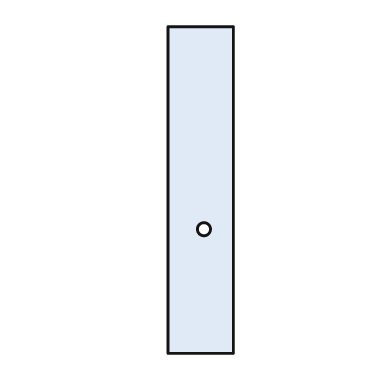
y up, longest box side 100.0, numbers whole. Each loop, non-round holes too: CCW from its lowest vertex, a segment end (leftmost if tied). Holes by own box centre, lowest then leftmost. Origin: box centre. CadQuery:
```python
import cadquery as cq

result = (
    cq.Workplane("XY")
    .moveTo(-10.0, -50.0)
    .lineTo(10.0, -50.0)
    .lineTo(10.0, 50.0)
    .lineTo(-10.0, 50.0)
    .close()
    .moveTo(1.0, -12.0)
    .circle(2.0)
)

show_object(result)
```